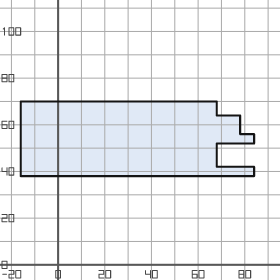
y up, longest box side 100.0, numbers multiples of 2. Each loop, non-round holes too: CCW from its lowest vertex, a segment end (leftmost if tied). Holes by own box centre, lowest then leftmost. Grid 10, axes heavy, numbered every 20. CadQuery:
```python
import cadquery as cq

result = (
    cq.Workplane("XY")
    .moveTo(-16.0, 38.0)
    .lineTo(84.0, 38.0)
    .lineTo(84.0, 42.0)
    .lineTo(68.0, 42.0)
    .lineTo(68.0, 52.0)
    .lineTo(84.0, 52.0)
    .lineTo(84.0, 56.0)
    .lineTo(78.0, 56.0)
    .lineTo(78.0, 64.0)
    .lineTo(68.0, 64.0)
    .lineTo(68.0, 70.0)
    .lineTo(-16.0, 70.0)
    .close()
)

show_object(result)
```